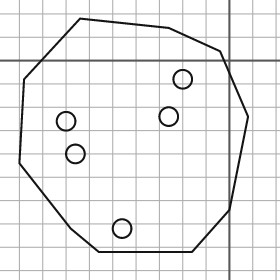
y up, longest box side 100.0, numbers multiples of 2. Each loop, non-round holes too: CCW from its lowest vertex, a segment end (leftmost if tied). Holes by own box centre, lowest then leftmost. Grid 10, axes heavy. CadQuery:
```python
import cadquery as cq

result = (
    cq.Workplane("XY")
    .moveTo(-56.0, -82.0)
    .lineTo(-16.0, -82.0)
    .lineTo(0.0, -64.0)
    .lineTo(8.0, -24.0)
    .lineTo(-4.0, 4.0)
    .lineTo(-26.0, 14.0)
    .lineTo(-64.0, 18.0)
    .lineTo(-88.0, -8.0)
    .lineTo(-90.0, -44.0)
    .lineTo(-68.0, -72.0)
    .close()
    .moveTo(-46.0, -72.0)
    .circle(4.0)
    .moveTo(-66.0, -40.0)
    .circle(4.0)
    .moveTo(-70.0, -26.0)
    .circle(4.0)
    .moveTo(-26.0, -24.0)
    .circle(4.0)
    .moveTo(-20.0, -8.0)
    .circle(4.0)
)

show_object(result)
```